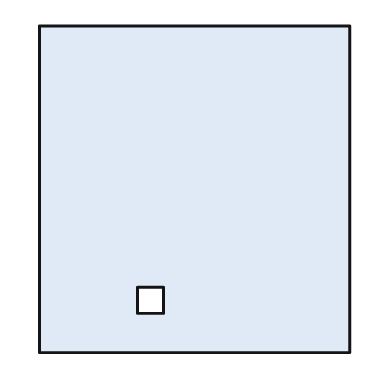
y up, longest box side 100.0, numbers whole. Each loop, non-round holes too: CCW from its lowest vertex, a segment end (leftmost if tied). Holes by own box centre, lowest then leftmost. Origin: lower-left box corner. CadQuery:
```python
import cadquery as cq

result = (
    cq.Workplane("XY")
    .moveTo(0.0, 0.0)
    .lineTo(95.0, 0.0)
    .lineTo(95.0, 100.0)
    .lineTo(0.0, 100.0)
    .close()
    .moveTo(30.0, 12.0)
    .lineTo(38.0, 12.0)
    .lineTo(38.0, 20.0)
    .lineTo(30.0, 20.0)
    .close()
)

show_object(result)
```